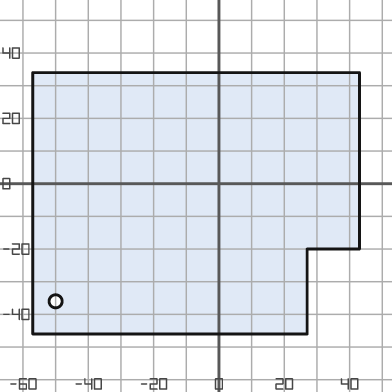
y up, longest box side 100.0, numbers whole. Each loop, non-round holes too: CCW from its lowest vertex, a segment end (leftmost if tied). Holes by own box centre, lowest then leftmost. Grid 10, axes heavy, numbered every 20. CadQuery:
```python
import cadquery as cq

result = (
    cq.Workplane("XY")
    .moveTo(-57.0, -46.0)
    .lineTo(27.0, -46.0)
    .lineTo(27.0, -20.0)
    .lineTo(43.0, -20.0)
    .lineTo(43.0, 34.0)
    .lineTo(-57.0, 34.0)
    .close()
    .moveTo(-50.0, -36.0)
    .circle(2.0)
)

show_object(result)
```